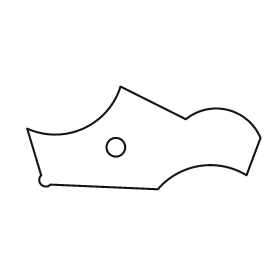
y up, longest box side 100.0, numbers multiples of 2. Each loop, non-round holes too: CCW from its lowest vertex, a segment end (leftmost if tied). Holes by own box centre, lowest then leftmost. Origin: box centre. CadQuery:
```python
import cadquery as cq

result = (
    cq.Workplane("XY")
    .moveTo(6.0, -22.0)
    .threePointArc((24.0, -12.0), (44.0, -16.0))
    .lineTo(50.0, 0.0)
    .threePointArc((36.0, 12.0), (18.0, 8.0))
    .lineTo(-10.0, 22.0)
    .threePointArc((-26.0, 4.0), (-50.0, 4.0))
    .lineTo(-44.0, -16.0)
    .threePointArc((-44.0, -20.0), (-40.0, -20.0))
    .close()
    .moveTo(-12.0, -4.0)
    .circle(4.0)
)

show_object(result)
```